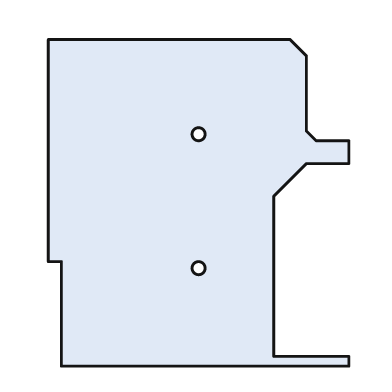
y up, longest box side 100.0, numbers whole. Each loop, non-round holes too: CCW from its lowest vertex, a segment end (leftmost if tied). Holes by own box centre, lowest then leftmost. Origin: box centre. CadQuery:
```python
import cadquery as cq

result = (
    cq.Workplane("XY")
    .moveTo(-42.0, -50.0)
    .lineTo(46.0, -50.0)
    .lineTo(46.0, -47.0)
    .lineTo(23.0, -47.0)
    .lineTo(23.0, 2.0)
    .lineTo(33.0, 12.0)
    .lineTo(46.0, 12.0)
    .lineTo(46.0, 19.0)
    .lineTo(36.0, 19.0)
    .lineTo(33.0, 22.0)
    .lineTo(33.0, 45.0)
    .lineTo(28.0, 50.0)
    .lineTo(-46.0, 50.0)
    .lineTo(-46.0, -18.0)
    .lineTo(-42.0, -18.0)
    .close()
    .moveTo(0.0, -20.0)
    .circle(2.0)
    .moveTo(0.0, 21.0)
    .circle(2.0)
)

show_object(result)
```